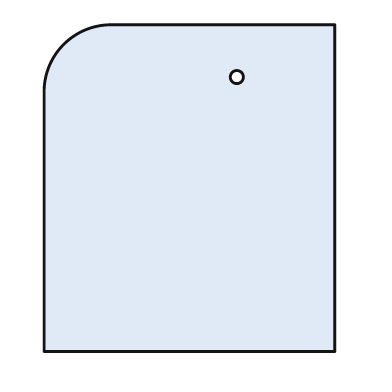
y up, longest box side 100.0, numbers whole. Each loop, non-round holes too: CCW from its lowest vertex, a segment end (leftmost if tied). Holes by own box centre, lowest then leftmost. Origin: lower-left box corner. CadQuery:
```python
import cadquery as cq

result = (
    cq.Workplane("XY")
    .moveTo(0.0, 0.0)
    .lineTo(89.0, 0.0)
    .lineTo(89.0, 100.0)
    .lineTo(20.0, 100.0)
    .threePointArc((6.0, 94.0), (0.0, 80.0))
    .close()
    .moveTo(59.0, 84.0)
    .circle(2.0)
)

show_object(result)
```